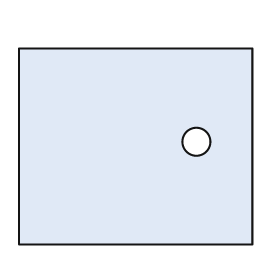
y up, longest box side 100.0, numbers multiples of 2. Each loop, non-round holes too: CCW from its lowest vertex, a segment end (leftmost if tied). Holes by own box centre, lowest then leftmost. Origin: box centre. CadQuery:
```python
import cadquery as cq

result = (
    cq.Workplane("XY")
    .moveTo(-50.0, -42.0)
    .lineTo(50.0, -42.0)
    .lineTo(50.0, 42.0)
    .lineTo(-50.0, 42.0)
    .close()
    .moveTo(26.0, 2.0)
    .circle(6.0)
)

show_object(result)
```